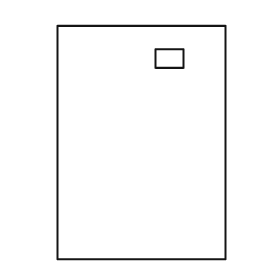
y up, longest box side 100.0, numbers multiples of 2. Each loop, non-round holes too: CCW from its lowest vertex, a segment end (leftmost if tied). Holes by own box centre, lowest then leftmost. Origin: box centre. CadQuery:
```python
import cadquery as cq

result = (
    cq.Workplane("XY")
    .moveTo(-36.0, -50.0)
    .lineTo(36.0, -50.0)
    .lineTo(36.0, 50.0)
    .lineTo(-36.0, 50.0)
    .close()
    .moveTo(6.0, 32.0)
    .lineTo(18.0, 32.0)
    .lineTo(18.0, 40.0)
    .lineTo(6.0, 40.0)
    .close()
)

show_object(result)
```